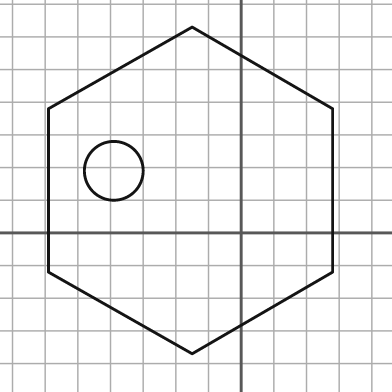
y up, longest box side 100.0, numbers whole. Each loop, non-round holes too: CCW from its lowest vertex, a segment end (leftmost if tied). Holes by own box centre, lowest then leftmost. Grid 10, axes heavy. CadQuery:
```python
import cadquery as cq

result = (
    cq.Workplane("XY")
    .moveTo(-15.0, -37.0)
    .lineTo(28.0, -12.0)
    .lineTo(28.0, 38.0)
    .lineTo(-15.0, 63.0)
    .lineTo(-59.0, 38.0)
    .lineTo(-59.0, -12.0)
    .close()
    .moveTo(-39.0, 19.0)
    .circle(9.0)
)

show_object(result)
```